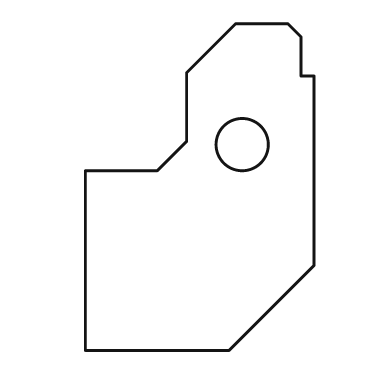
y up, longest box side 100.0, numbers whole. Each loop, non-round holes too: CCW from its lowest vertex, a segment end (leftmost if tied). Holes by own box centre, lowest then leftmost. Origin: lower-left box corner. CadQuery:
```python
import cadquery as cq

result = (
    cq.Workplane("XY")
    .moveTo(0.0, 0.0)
    .lineTo(44.0, 0.0)
    .lineTo(70.0, 26.0)
    .lineTo(70.0, 84.0)
    .lineTo(66.0, 84.0)
    .lineTo(66.0, 96.0)
    .lineTo(62.0, 100.0)
    .lineTo(46.0, 100.0)
    .lineTo(31.0, 85.0)
    .lineTo(31.0, 64.0)
    .lineTo(22.0, 55.0)
    .lineTo(0.0, 55.0)
    .close()
    .moveTo(48.0, 63.0)
    .circle(8.0)
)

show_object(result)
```